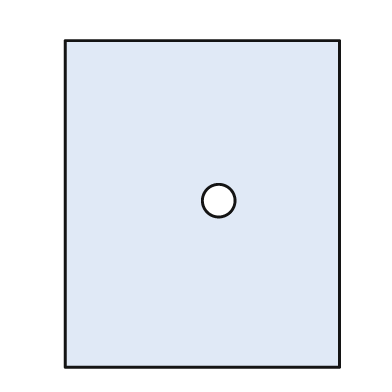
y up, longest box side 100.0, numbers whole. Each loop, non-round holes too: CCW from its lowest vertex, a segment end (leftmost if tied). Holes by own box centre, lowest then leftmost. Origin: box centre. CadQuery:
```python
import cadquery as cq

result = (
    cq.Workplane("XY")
    .moveTo(-42.0, -50.0)
    .lineTo(42.0, -50.0)
    .lineTo(42.0, 50.0)
    .lineTo(-42.0, 50.0)
    .close()
    .moveTo(5.0, 1.0)
    .circle(5.0)
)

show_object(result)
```